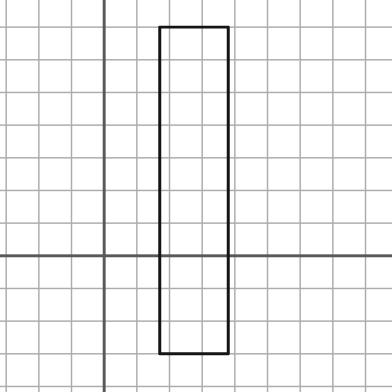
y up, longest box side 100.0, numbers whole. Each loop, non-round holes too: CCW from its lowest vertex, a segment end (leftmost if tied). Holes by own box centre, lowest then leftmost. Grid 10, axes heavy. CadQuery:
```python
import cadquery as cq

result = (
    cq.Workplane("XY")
    .moveTo(17.0, -30.0)
    .lineTo(38.0, -30.0)
    .lineTo(38.0, 70.0)
    .lineTo(17.0, 70.0)
    .close()
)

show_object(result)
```